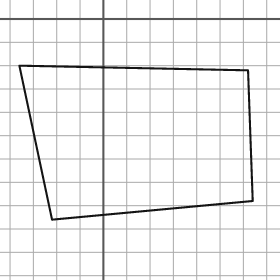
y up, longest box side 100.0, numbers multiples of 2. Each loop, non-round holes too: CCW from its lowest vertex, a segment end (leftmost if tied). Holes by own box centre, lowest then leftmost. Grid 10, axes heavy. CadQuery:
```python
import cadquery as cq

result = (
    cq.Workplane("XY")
    .moveTo(-22.0, -86.0)
    .lineTo(64.0, -78.0)
    .lineTo(62.0, -22.0)
    .lineTo(-36.0, -20.0)
    .close()
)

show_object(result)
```